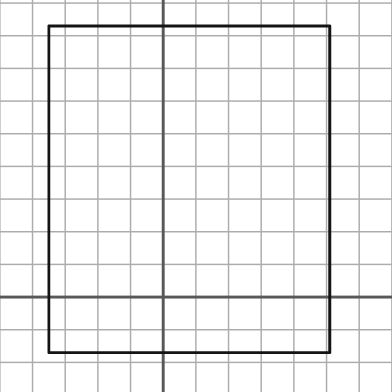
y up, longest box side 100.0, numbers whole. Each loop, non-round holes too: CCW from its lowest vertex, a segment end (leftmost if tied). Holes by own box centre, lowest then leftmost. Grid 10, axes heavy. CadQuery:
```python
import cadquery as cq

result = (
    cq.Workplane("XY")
    .moveTo(-35.0, -17.0)
    .lineTo(51.0, -17.0)
    .lineTo(51.0, 83.0)
    .lineTo(-35.0, 83.0)
    .close()
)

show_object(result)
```